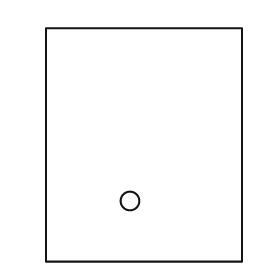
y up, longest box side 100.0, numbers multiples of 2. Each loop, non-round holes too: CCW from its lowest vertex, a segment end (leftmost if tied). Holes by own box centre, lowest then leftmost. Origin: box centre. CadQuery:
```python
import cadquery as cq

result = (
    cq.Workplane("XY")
    .moveTo(-42.0, -50.0)
    .lineTo(42.0, -50.0)
    .lineTo(42.0, 50.0)
    .lineTo(-42.0, 50.0)
    .close()
    .moveTo(-6.0, -24.0)
    .circle(4.0)
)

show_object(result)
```